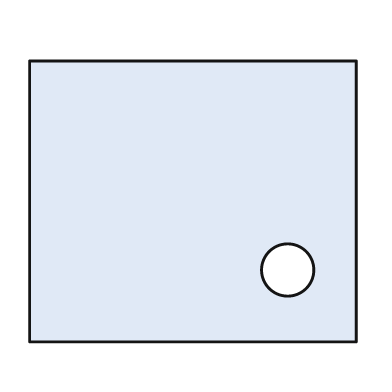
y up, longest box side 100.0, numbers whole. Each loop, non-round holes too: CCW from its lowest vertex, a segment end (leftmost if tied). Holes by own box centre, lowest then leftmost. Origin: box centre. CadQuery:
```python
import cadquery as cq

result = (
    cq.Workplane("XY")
    .moveTo(-50.0, -43.0)
    .lineTo(50.0, -43.0)
    .lineTo(50.0, 43.0)
    .lineTo(-50.0, 43.0)
    .close()
    .moveTo(29.0, -21.0)
    .circle(8.0)
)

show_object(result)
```